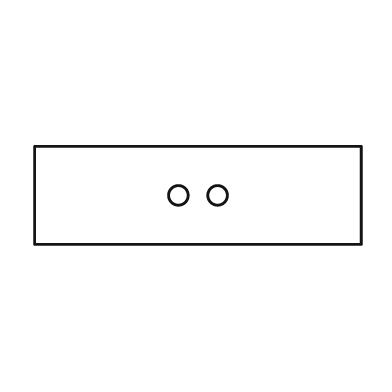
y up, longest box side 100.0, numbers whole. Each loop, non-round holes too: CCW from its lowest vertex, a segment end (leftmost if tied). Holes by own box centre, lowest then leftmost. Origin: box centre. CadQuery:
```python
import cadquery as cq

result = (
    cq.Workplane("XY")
    .moveTo(-50.0, -15.0)
    .lineTo(50.0, -15.0)
    .lineTo(50.0, 15.0)
    .lineTo(-50.0, 15.0)
    .close()
    .moveTo(-6.0, 0.0)
    .circle(3.0)
    .moveTo(6.0, 0.0)
    .circle(3.0)
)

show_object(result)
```